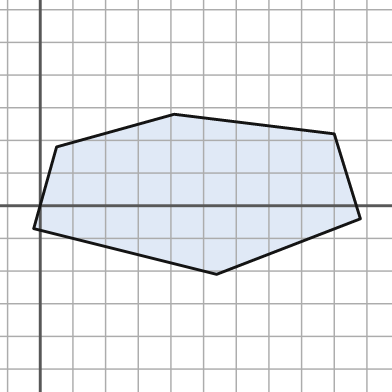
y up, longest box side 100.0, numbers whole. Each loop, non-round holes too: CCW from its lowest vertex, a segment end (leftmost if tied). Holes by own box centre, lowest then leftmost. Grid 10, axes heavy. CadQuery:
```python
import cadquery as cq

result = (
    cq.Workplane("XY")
    .moveTo(54.0, -21.0)
    .lineTo(98.0, -4.0)
    .lineTo(90.0, 22.0)
    .lineTo(41.0, 28.0)
    .lineTo(5.0, 18.0)
    .lineTo(-2.0, -7.0)
    .close()
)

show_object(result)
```